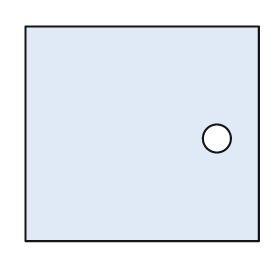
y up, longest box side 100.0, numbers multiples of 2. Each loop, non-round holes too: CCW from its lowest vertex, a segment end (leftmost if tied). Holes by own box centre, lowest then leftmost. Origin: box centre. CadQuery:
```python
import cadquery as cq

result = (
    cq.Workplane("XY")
    .moveTo(-50.0, -46.0)
    .lineTo(50.0, -46.0)
    .lineTo(50.0, 46.0)
    .lineTo(-50.0, 46.0)
    .close()
    .moveTo(32.0, -2.0)
    .circle(6.0)
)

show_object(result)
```